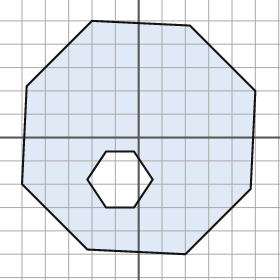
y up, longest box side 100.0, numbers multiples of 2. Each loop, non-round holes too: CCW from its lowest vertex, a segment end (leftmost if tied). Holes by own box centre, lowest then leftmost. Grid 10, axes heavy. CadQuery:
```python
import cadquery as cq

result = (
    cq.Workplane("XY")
    .moveTo(20.0, -50.0)
    .lineTo(48.0, -22.0)
    .lineTo(50.0, 20.0)
    .lineTo(22.0, 48.0)
    .lineTo(-20.0, 50.0)
    .lineTo(-48.0, 22.0)
    .lineTo(-50.0, -20.0)
    .lineTo(-22.0, -48.0)
    .close()
    .moveTo(-14.0, -30.0)
    .lineTo(-2.0, -30.0)
    .lineTo(6.0, -18.0)
    .lineTo(-2.0, -6.0)
    .lineTo(-14.0, -6.0)
    .lineTo(-22.0, -18.0)
    .close()
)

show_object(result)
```